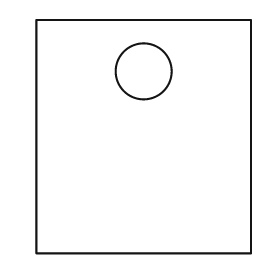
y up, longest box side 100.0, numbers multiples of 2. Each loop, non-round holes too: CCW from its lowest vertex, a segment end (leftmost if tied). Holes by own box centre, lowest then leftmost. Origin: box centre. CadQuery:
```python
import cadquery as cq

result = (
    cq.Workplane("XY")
    .moveTo(-46.0, -50.0)
    .lineTo(46.0, -50.0)
    .lineTo(46.0, 50.0)
    .lineTo(-46.0, 50.0)
    .close()
    .moveTo(0.0, 28.0)
    .circle(12.0)
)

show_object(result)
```